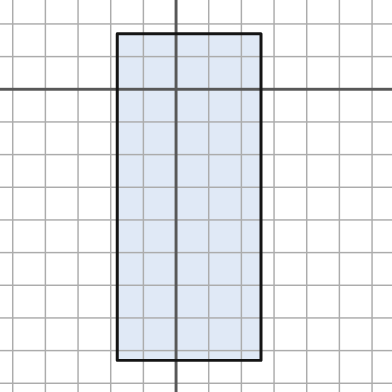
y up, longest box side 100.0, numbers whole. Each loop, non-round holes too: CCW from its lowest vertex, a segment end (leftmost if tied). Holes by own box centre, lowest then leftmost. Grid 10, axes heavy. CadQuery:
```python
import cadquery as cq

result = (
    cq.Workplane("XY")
    .moveTo(-18.0, -83.0)
    .lineTo(26.0, -83.0)
    .lineTo(26.0, 17.0)
    .lineTo(-18.0, 17.0)
    .close()
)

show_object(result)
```